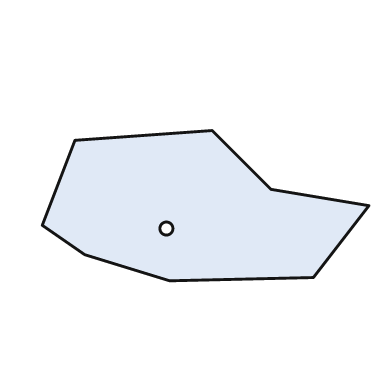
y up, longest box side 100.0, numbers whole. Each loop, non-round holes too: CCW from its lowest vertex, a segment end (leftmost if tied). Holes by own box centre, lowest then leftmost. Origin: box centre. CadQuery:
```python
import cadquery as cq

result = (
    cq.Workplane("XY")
    .moveTo(-11.0, -23.0)
    .lineTo(33.0, -22.0)
    .lineTo(50.0, 0.0)
    .lineTo(20.0, 5.0)
    .lineTo(2.0, 23.0)
    .lineTo(-40.0, 20.0)
    .lineTo(-50.0, -6.0)
    .lineTo(-37.0, -15.0)
    .close()
    .moveTo(-12.0, -7.0)
    .circle(2.0)
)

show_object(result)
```